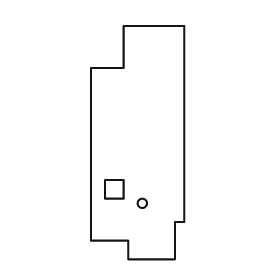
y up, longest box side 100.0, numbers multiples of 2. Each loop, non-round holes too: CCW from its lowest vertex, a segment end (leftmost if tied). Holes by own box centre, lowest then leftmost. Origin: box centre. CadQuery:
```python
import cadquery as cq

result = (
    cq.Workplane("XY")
    .moveTo(-4.0, -50.0)
    .lineTo(16.0, -50.0)
    .lineTo(16.0, -34.0)
    .lineTo(20.0, -34.0)
    .lineTo(20.0, 50.0)
    .lineTo(-6.0, 50.0)
    .lineTo(-6.0, 32.0)
    .lineTo(-20.0, 32.0)
    .lineTo(-20.0, -42.0)
    .lineTo(-4.0, -42.0)
    .close()
    .moveTo(2.0, -26.0)
    .circle(2.0)
    .moveTo(-14.0, -24.0)
    .lineTo(-6.0, -24.0)
    .lineTo(-6.0, -16.0)
    .lineTo(-14.0, -16.0)
    .close()
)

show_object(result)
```